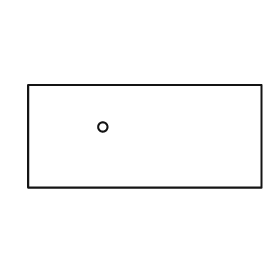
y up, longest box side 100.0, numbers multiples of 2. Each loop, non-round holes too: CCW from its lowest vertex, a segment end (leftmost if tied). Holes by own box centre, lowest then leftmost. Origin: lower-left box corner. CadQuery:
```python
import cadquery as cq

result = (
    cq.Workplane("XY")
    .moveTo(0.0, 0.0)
    .lineTo(100.0, 0.0)
    .lineTo(100.0, 44.0)
    .lineTo(0.0, 44.0)
    .close()
    .moveTo(32.0, 26.0)
    .circle(2.0)
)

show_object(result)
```